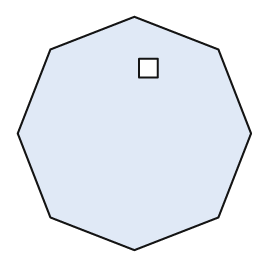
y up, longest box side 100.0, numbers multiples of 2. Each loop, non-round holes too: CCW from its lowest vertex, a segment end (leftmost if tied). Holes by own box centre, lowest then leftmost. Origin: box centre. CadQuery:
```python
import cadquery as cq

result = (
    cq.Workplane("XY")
    .moveTo(0.0, -50.0)
    .lineTo(36.0, -36.0)
    .lineTo(50.0, 0.0)
    .lineTo(36.0, 36.0)
    .lineTo(0.0, 50.0)
    .lineTo(-36.0, 36.0)
    .lineTo(-50.0, 0.0)
    .lineTo(-36.0, -36.0)
    .close()
    .moveTo(2.0, 24.0)
    .lineTo(10.0, 24.0)
    .lineTo(10.0, 32.0)
    .lineTo(2.0, 32.0)
    .close()
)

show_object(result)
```